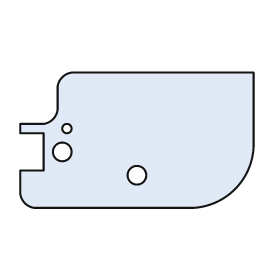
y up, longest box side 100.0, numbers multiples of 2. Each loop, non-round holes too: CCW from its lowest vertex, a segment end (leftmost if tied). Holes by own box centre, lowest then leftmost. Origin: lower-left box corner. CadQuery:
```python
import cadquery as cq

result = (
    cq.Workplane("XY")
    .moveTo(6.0, 0.0)
    .lineTo(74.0, 0.0)
    .threePointArc((92.0, 8.0), (100.0, 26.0))
    .lineTo(100.0, 58.0)
    .lineTo(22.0, 58.0)
    .threePointArc((18.0, 56.0), (16.0, 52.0))
    .lineTo(16.0, 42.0)
    .threePointArc((14.0, 38.0), (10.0, 36.0))
    .lineTo(0.0, 36.0)
    .lineTo(0.0, 32.0)
    .lineTo(10.0, 32.0)
    .lineTo(10.0, 16.0)
    .lineTo(0.0, 16.0)
    .lineTo(0.0, 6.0)
    .threePointArc((2.0, 2.0), (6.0, 0.0))
    .close()
    .moveTo(50.0, 14.0)
    .circle(4.0)
    .moveTo(18.0, 24.0)
    .circle(4.0)
    .moveTo(20.0, 34.0)
    .circle(2.0)
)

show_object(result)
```